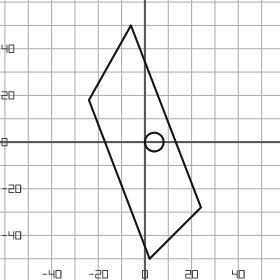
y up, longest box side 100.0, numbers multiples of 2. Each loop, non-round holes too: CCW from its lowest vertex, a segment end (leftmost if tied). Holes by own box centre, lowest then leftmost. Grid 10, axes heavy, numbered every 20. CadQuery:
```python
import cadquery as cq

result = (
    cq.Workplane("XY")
    .moveTo(2.0, -50.0)
    .lineTo(24.0, -28.0)
    .lineTo(-6.0, 50.0)
    .lineTo(-24.0, 18.0)
    .close()
    .moveTo(4.0, 0.0)
    .circle(4.0)
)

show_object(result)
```